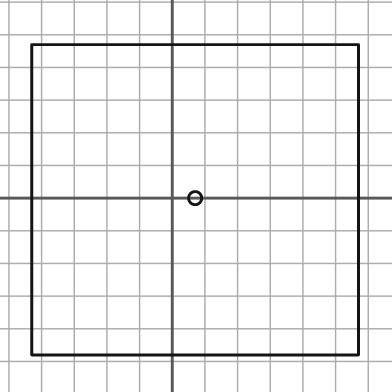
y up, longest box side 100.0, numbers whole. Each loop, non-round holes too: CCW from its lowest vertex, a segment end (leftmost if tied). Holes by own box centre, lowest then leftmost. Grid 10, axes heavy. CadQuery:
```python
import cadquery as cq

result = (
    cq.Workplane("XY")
    .moveTo(-43.0, -48.0)
    .lineTo(57.0, -48.0)
    .lineTo(57.0, 47.0)
    .lineTo(-43.0, 47.0)
    .close()
    .moveTo(7.0, 0.0)
    .circle(2.0)
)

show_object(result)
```